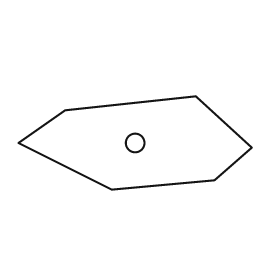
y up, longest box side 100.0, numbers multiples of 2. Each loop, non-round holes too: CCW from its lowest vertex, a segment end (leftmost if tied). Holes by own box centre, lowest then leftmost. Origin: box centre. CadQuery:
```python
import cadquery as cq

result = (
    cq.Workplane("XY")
    .moveTo(-10.0, -20.0)
    .lineTo(34.0, -16.0)
    .lineTo(50.0, -2.0)
    .lineTo(26.0, 20.0)
    .lineTo(-30.0, 14.0)
    .lineTo(-50.0, 0.0)
    .close()
    .moveTo(0.0, 0.0)
    .circle(4.0)
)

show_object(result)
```